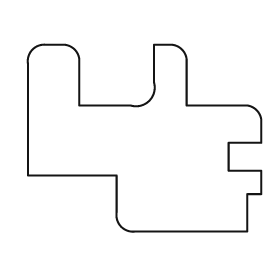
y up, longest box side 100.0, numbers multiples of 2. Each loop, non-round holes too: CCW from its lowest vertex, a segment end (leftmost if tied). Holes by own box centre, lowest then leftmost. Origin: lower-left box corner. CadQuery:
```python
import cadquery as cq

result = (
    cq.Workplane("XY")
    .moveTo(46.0, 0.0)
    .lineTo(94.0, 0.0)
    .lineTo(94.0, 16.0)
    .lineTo(100.0, 16.0)
    .lineTo(100.0, 26.0)
    .lineTo(86.0, 26.0)
    .lineTo(86.0, 38.0)
    .lineTo(100.0, 38.0)
    .lineTo(100.0, 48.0)
    .threePointArc((98.0, 52.0), (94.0, 54.0))
    .lineTo(68.0, 54.0)
    .lineTo(68.0, 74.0)
    .threePointArc((66.0, 78.0), (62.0, 80.0))
    .lineTo(54.0, 80.0)
    .lineTo(54.0, 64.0)
    .threePointArc((52.0, 56.0), (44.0, 54.0))
    .lineTo(22.0, 54.0)
    .lineTo(22.0, 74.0)
    .threePointArc((20.0, 78.0), (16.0, 80.0))
    .lineTo(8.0, 80.0)
    .threePointArc((2.0, 78.0), (0.0, 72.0))
    .lineTo(0.0, 24.0)
    .lineTo(38.0, 24.0)
    .lineTo(38.0, 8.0)
    .threePointArc((40.0, 2.0), (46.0, 0.0))
    .close()
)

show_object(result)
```